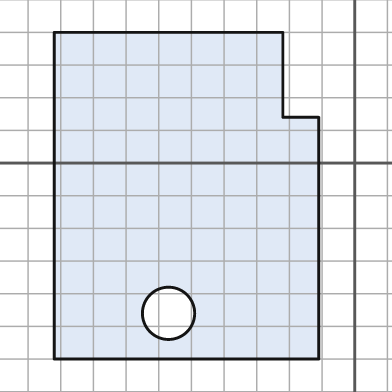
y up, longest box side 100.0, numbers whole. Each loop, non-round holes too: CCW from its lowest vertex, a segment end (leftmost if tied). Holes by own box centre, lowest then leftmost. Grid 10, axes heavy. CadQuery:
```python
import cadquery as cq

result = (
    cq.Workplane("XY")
    .moveTo(-92.0, -60.0)
    .lineTo(-11.0, -60.0)
    .lineTo(-11.0, 14.0)
    .lineTo(-22.0, 14.0)
    .lineTo(-22.0, 40.0)
    .lineTo(-92.0, 40.0)
    .close()
    .moveTo(-57.0, -46.0)
    .circle(8.0)
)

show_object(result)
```